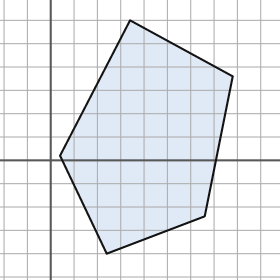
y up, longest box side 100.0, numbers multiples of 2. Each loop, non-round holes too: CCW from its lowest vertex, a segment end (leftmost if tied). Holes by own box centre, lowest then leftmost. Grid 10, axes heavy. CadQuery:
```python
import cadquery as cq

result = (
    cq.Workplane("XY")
    .moveTo(24.0, -40.0)
    .lineTo(66.0, -24.0)
    .lineTo(78.0, 36.0)
    .lineTo(34.0, 60.0)
    .lineTo(4.0, 2.0)
    .close()
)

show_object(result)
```